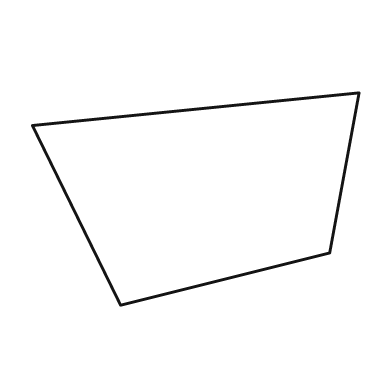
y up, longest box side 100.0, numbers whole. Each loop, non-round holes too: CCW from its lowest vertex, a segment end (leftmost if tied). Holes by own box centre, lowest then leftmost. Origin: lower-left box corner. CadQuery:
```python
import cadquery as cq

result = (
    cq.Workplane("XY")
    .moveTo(27.0, 0.0)
    .lineTo(91.0, 16.0)
    .lineTo(100.0, 65.0)
    .lineTo(0.0, 55.0)
    .close()
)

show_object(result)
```